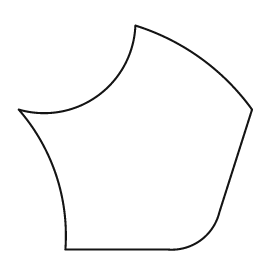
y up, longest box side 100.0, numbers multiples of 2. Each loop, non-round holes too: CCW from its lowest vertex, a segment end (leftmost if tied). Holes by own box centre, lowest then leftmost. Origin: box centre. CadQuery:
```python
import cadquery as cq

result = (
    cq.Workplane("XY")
    .moveTo(-30.0, -48.0)
    .lineTo(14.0, -48.0)
    .threePointArc((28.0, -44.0), (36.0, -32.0))
    .lineTo(50.0, 12.0)
    .threePointArc((28.0, 34.0), (0.0, 48.0))
    .threePointArc((-16.0, 18.0), (-50.0, 12.0))
    .threePointArc((-34.0, -16.0), (-30.0, -48.0))
    .close()
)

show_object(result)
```